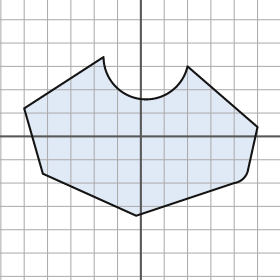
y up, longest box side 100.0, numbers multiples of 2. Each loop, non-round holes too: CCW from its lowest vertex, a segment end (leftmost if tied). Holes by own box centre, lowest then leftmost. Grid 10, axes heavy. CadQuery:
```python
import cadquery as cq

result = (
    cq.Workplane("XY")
    .moveTo(-2.0, -34.0)
    .lineTo(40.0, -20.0)
    .threePointArc((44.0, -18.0), (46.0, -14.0))
    .lineTo(50.0, 4.0)
    .lineTo(20.0, 30.0)
    .threePointArc((0.0, 16.0), (-16.0, 34.0))
    .lineTo(-50.0, 12.0)
    .lineTo(-42.0, -16.0)
    .close()
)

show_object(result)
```